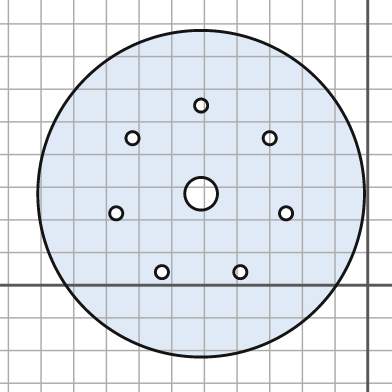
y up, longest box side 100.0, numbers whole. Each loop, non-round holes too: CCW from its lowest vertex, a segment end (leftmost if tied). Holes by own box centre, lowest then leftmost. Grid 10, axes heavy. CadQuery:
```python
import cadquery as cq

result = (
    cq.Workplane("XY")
    .moveTo(-51.0, 28.0)
    .circle(50.0)
    .moveTo(-63.0, 4.0)
    .circle(2.0)
    .moveTo(-39.0, 4.0)
    .circle(2.0)
    .moveTo(-77.0, 22.0)
    .circle(2.0)
    .moveTo(-25.0, 22.0)
    .circle(2.0)
    .moveTo(-51.0, 28.0)
    .circle(5.0)
    .moveTo(-72.0, 45.0)
    .circle(2.0)
    .moveTo(-30.0, 45.0)
    .circle(2.0)
    .moveTo(-51.0, 55.0)
    .circle(2.0)
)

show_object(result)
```